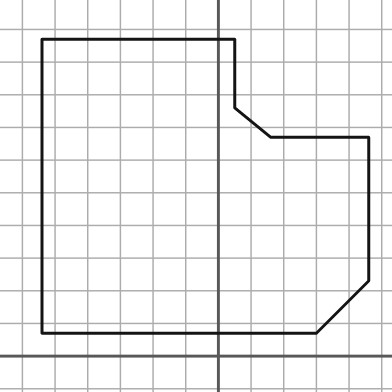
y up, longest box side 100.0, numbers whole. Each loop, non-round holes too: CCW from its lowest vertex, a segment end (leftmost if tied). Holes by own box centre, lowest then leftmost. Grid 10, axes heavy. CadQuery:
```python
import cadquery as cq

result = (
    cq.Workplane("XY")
    .moveTo(-54.0, 7.0)
    .lineTo(30.0, 7.0)
    .lineTo(46.0, 23.0)
    .lineTo(46.0, 67.0)
    .lineTo(16.0, 67.0)
    .lineTo(5.0, 76.0)
    .lineTo(5.0, 97.0)
    .lineTo(-54.0, 97.0)
    .close()
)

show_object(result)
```